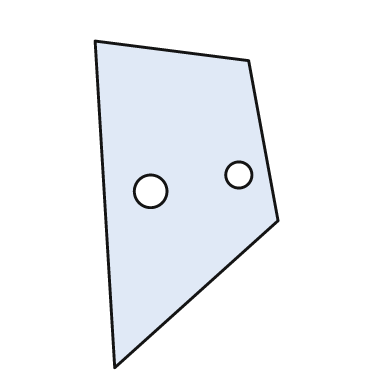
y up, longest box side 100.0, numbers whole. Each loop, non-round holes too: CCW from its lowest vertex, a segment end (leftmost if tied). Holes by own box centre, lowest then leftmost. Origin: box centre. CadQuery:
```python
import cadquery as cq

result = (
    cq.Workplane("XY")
    .moveTo(-22.0, -50.0)
    .lineTo(28.0, -5.0)
    .lineTo(19.0, 44.0)
    .lineTo(-28.0, 50.0)
    .close()
    .moveTo(-11.0, 4.0)
    .circle(5.0)
    .moveTo(16.0, 9.0)
    .circle(4.0)
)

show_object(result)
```